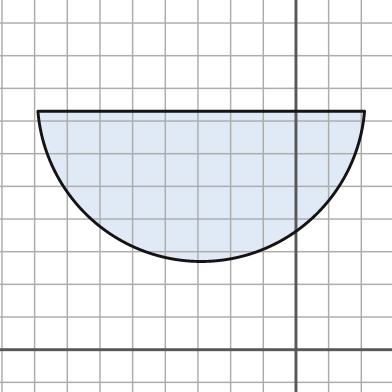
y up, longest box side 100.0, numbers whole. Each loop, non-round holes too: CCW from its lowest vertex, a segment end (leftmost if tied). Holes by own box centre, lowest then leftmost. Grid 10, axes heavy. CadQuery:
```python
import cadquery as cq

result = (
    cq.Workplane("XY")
    .moveTo(-79.0, 73.0)
    .threePointArc((-29.0, 27.0), (21.0, 73.0))
    .close()
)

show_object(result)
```